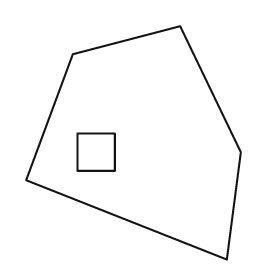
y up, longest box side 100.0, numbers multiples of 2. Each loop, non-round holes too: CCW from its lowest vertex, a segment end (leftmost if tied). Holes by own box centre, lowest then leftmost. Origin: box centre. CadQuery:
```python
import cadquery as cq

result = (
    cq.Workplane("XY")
    .moveTo(40.0, -50.0)
    .lineTo(46.0, -4.0)
    .lineTo(20.0, 50.0)
    .lineTo(-26.0, 38.0)
    .lineTo(-46.0, -16.0)
    .close()
    .moveTo(-24.0, -12.0)
    .lineTo(-8.0, -12.0)
    .lineTo(-8.0, 4.0)
    .lineTo(-24.0, 4.0)
    .close()
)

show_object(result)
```